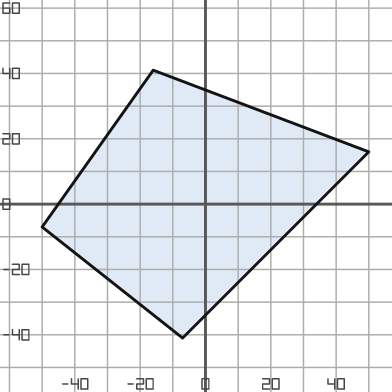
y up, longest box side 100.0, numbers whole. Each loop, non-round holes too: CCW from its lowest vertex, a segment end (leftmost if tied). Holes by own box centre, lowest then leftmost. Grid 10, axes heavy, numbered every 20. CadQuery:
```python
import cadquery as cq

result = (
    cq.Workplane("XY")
    .moveTo(-7.0, -41.0)
    .lineTo(50.0, 16.0)
    .lineTo(-16.0, 41.0)
    .lineTo(-50.0, -7.0)
    .close()
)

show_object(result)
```